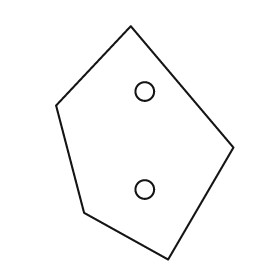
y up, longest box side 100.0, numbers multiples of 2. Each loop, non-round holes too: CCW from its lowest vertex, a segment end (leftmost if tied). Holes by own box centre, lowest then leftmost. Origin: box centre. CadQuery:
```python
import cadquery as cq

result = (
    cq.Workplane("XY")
    .moveTo(10.0, -50.0)
    .lineTo(38.0, -2.0)
    .lineTo(-6.0, 50.0)
    .lineTo(-38.0, 16.0)
    .lineTo(-26.0, -30.0)
    .close()
    .moveTo(0.0, -20.0)
    .circle(4.0)
    .moveTo(0.0, 22.0)
    .circle(4.0)
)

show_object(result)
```